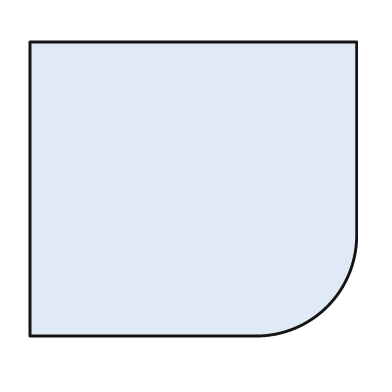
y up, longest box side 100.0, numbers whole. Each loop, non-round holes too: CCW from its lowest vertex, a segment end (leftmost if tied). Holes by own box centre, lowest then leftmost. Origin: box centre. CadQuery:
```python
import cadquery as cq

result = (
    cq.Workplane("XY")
    .moveTo(-50.0, -45.0)
    .lineTo(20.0, -45.0)
    .threePointArc((41.0, -36.0), (50.0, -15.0))
    .lineTo(50.0, 45.0)
    .lineTo(-50.0, 45.0)
    .close()
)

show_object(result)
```